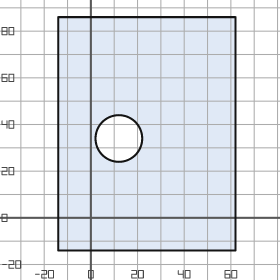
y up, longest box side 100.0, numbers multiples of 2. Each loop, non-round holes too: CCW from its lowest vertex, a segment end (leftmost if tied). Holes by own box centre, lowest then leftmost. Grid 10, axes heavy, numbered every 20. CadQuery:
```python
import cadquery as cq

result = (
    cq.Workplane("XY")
    .moveTo(-14.0, -14.0)
    .lineTo(62.0, -14.0)
    .lineTo(62.0, 86.0)
    .lineTo(-14.0, 86.0)
    .close()
    .moveTo(12.0, 34.0)
    .circle(10.0)
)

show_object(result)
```